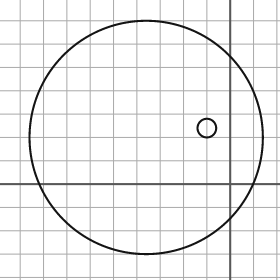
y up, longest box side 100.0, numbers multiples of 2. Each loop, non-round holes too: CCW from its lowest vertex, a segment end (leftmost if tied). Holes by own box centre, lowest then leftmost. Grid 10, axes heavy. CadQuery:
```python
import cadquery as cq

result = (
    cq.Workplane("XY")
    .moveTo(-36.0, 20.0)
    .circle(50.0)
    .moveTo(-10.0, 24.0)
    .circle(4.0)
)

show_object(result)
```